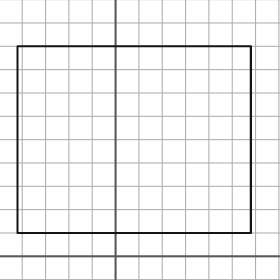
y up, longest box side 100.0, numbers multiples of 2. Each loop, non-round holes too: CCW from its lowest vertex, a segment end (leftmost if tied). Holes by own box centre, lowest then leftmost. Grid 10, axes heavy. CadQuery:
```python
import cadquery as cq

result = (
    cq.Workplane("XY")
    .moveTo(-42.0, 10.0)
    .lineTo(58.0, 10.0)
    .lineTo(58.0, 90.0)
    .lineTo(-42.0, 90.0)
    .close()
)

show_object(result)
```